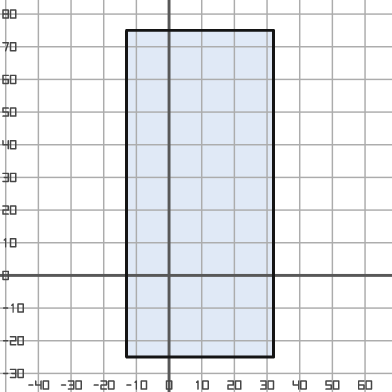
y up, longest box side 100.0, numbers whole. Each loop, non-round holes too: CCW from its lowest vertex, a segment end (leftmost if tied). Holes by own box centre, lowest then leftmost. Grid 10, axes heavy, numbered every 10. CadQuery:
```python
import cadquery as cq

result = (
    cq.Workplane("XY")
    .moveTo(-13.0, -25.0)
    .lineTo(32.0, -25.0)
    .lineTo(32.0, 75.0)
    .lineTo(-13.0, 75.0)
    .close()
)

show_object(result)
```